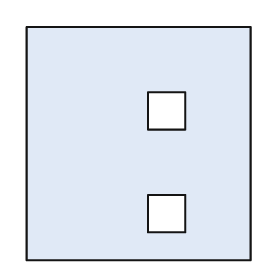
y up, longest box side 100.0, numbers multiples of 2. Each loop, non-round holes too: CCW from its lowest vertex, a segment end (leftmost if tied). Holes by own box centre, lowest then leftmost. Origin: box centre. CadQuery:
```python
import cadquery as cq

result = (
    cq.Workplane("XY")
    .moveTo(-48.0, -50.0)
    .lineTo(48.0, -50.0)
    .lineTo(48.0, 50.0)
    .lineTo(-48.0, 50.0)
    .close()
    .moveTo(4.0, -38.0)
    .lineTo(20.0, -38.0)
    .lineTo(20.0, -22.0)
    .lineTo(4.0, -22.0)
    .close()
    .moveTo(4.0, 6.0)
    .lineTo(20.0, 6.0)
    .lineTo(20.0, 22.0)
    .lineTo(4.0, 22.0)
    .close()
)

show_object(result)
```